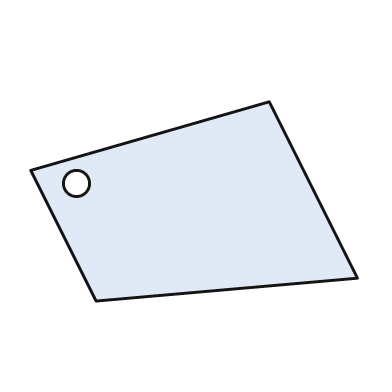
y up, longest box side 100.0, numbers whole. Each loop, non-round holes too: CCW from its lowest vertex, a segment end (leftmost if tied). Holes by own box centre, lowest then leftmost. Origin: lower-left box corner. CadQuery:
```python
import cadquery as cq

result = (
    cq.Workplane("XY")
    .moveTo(20.0, 0.0)
    .lineTo(100.0, 7.0)
    .lineTo(73.0, 61.0)
    .lineTo(0.0, 40.0)
    .close()
    .moveTo(14.0, 36.0)
    .circle(4.0)
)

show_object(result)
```